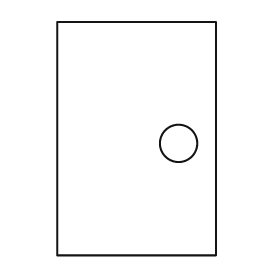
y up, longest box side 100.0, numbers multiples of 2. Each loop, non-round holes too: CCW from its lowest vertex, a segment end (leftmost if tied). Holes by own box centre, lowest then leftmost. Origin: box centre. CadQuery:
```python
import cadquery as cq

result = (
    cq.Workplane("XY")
    .moveTo(-34.0, -50.0)
    .lineTo(34.0, -50.0)
    .lineTo(34.0, 50.0)
    .lineTo(-34.0, 50.0)
    .close()
    .moveTo(18.0, -2.0)
    .circle(8.0)
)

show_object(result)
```